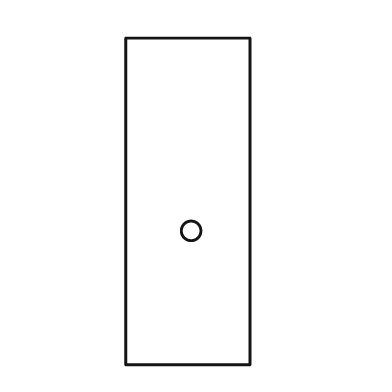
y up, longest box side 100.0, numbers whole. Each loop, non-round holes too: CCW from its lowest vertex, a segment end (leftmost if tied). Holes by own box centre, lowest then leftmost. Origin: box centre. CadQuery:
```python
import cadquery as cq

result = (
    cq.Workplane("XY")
    .moveTo(-19.0, -50.0)
    .lineTo(19.0, -50.0)
    .lineTo(19.0, 50.0)
    .lineTo(-19.0, 50.0)
    .close()
    .moveTo(1.0, -9.0)
    .circle(3.0)
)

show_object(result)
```